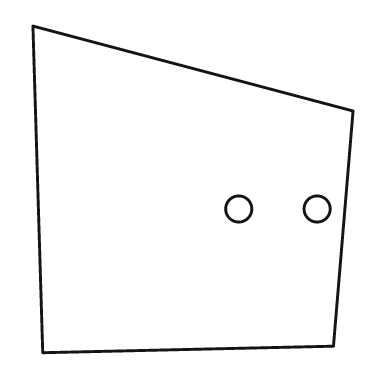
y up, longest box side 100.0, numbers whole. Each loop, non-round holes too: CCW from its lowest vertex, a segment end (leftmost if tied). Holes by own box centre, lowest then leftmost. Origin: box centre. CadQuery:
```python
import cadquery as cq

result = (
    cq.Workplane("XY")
    .moveTo(-46.0, -50.0)
    .lineTo(43.0, -48.0)
    .lineTo(49.0, 24.0)
    .lineTo(-49.0, 50.0)
    .close()
    .moveTo(14.0, -6.0)
    .circle(4.0)
    .moveTo(38.0, -6.0)
    .circle(4.0)
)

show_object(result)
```